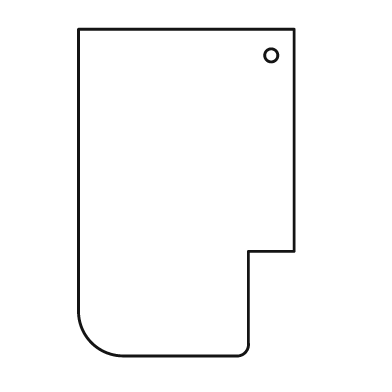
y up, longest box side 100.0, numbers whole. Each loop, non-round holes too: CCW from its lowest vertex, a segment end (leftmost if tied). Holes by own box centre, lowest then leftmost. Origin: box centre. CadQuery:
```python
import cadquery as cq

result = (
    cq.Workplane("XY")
    .moveTo(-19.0, -50.0)
    .lineTo(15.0, -50.0)
    .threePointArc((18.0, -49.0), (19.0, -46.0))
    .lineTo(19.0, -18.0)
    .lineTo(33.0, -18.0)
    .lineTo(33.0, 50.0)
    .lineTo(-33.0, 50.0)
    .lineTo(-33.0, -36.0)
    .threePointArc((-29.0, -46.0), (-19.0, -50.0))
    .close()
    .moveTo(26.0, 42.0)
    .circle(2.0)
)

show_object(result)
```